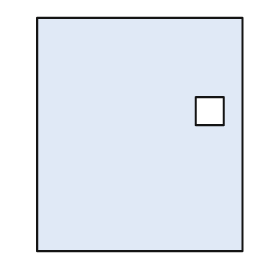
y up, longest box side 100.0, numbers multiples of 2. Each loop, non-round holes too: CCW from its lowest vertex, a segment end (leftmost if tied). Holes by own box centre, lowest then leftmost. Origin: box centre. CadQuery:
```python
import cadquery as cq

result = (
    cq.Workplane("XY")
    .moveTo(-44.0, -50.0)
    .lineTo(44.0, -50.0)
    .lineTo(44.0, 50.0)
    .lineTo(-44.0, 50.0)
    .close()
    .moveTo(24.0, 4.0)
    .lineTo(36.0, 4.0)
    .lineTo(36.0, 16.0)
    .lineTo(24.0, 16.0)
    .close()
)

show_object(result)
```